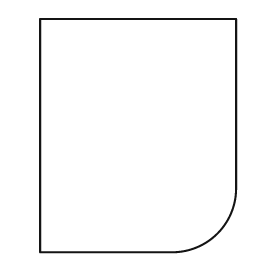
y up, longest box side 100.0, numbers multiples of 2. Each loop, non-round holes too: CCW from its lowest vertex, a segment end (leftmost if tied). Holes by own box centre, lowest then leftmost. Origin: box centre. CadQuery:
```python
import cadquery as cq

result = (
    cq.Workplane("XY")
    .moveTo(-42.0, -50.0)
    .lineTo(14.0, -50.0)
    .threePointArc((34.0, -42.0), (42.0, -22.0))
    .lineTo(42.0, 50.0)
    .lineTo(-42.0, 50.0)
    .close()
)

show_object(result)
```